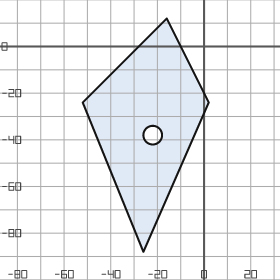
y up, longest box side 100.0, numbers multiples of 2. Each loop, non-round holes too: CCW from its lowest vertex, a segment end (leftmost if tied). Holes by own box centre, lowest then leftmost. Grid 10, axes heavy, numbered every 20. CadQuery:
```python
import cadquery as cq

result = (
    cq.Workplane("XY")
    .moveTo(-26.0, -88.0)
    .lineTo(2.0, -24.0)
    .lineTo(-16.0, 12.0)
    .lineTo(-52.0, -24.0)
    .close()
    .moveTo(-22.0, -38.0)
    .circle(4.0)
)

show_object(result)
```